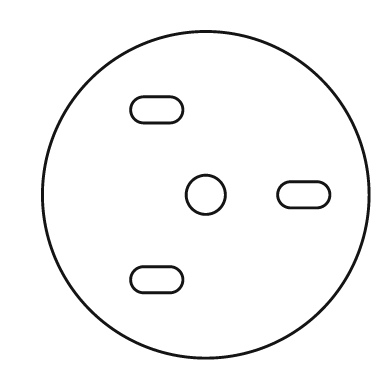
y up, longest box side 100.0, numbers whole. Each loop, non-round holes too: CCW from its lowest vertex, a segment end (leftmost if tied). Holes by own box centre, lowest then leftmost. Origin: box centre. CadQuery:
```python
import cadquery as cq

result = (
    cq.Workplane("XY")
    .moveTo(0.0, 0.0)
    .circle(50.0)
    .moveTo(-19.0, -30.0)
    .lineTo(-11.0, -30.0)
    .threePointArc((-7.0, -26.0), (-11.0, -22.0))
    .lineTo(-19.0, -22.0)
    .threePointArc((-23.0, -26.0), (-19.0, -30.0))
    .close()
    .moveTo(0.0, 0.0)
    .circle(6.0)
    .moveTo(26.0, -4.0)
    .lineTo(34.0, -4.0)
    .threePointArc((38.0, 0.0), (34.0, 4.0))
    .lineTo(26.0, 4.0)
    .threePointArc((22.0, 0.0), (26.0, -4.0))
    .close()
    .moveTo(-19.0, 22.0)
    .lineTo(-11.0, 22.0)
    .threePointArc((-7.0, 26.0), (-11.0, 30.0))
    .lineTo(-19.0, 30.0)
    .threePointArc((-23.0, 26.0), (-19.0, 22.0))
    .close()
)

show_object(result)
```